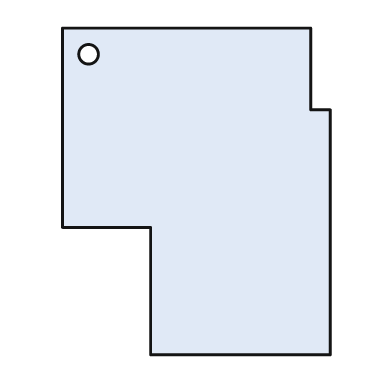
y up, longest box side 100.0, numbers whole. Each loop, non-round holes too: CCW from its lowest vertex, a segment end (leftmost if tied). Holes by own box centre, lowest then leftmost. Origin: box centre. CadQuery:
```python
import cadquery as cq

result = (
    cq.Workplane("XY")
    .moveTo(-14.0, -50.0)
    .lineTo(41.0, -50.0)
    .lineTo(41.0, 25.0)
    .lineTo(35.0, 25.0)
    .lineTo(35.0, 50.0)
    .lineTo(-41.0, 50.0)
    .lineTo(-41.0, -11.0)
    .lineTo(-14.0, -11.0)
    .close()
    .moveTo(-33.0, 42.0)
    .circle(3.0)
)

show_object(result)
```